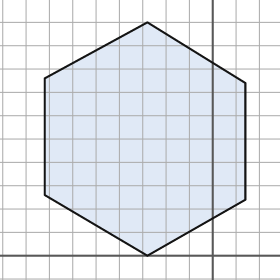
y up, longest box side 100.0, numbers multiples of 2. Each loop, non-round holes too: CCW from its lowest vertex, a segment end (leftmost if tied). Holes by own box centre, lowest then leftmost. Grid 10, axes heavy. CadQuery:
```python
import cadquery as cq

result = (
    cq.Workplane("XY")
    .moveTo(-28.0, 0.0)
    .lineTo(14.0, 24.0)
    .lineTo(14.0, 74.0)
    .lineTo(-28.0, 100.0)
    .lineTo(-72.0, 76.0)
    .lineTo(-72.0, 26.0)
    .close()
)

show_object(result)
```